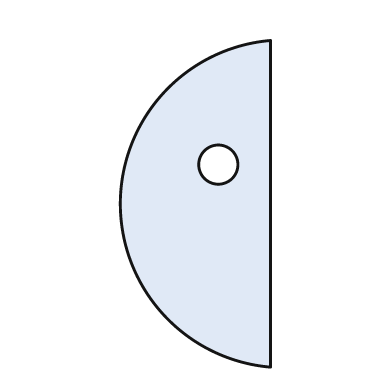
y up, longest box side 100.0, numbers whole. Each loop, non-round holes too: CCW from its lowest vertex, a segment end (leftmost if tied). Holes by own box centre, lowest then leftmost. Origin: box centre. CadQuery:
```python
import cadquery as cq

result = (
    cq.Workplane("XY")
    .moveTo(23.0, -50.0)
    .lineTo(23.0, 50.0)
    .threePointArc((-23.0, 0.0), (23.0, -50.0))
    .close()
    .moveTo(7.0, 12.0)
    .circle(6.0)
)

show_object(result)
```